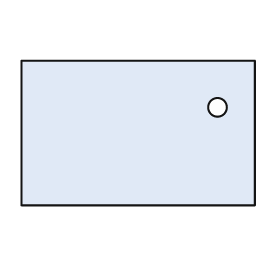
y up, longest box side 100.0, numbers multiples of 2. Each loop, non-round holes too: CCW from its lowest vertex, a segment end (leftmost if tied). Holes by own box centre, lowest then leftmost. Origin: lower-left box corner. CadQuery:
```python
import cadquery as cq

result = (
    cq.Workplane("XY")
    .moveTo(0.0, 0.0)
    .lineTo(100.0, 0.0)
    .lineTo(100.0, 62.0)
    .lineTo(0.0, 62.0)
    .close()
    .moveTo(84.0, 42.0)
    .circle(4.0)
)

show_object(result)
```